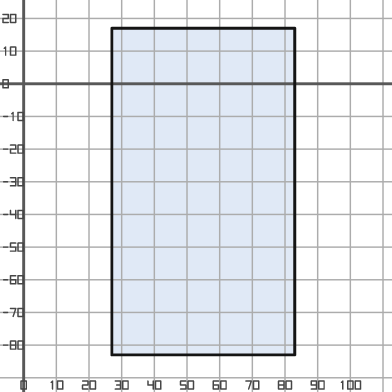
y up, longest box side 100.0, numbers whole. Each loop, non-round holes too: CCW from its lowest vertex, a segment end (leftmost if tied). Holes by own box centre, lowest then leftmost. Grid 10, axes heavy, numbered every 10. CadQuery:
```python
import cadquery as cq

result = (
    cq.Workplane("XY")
    .moveTo(27.0, -83.0)
    .lineTo(83.0, -83.0)
    .lineTo(83.0, 17.0)
    .lineTo(27.0, 17.0)
    .close()
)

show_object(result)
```